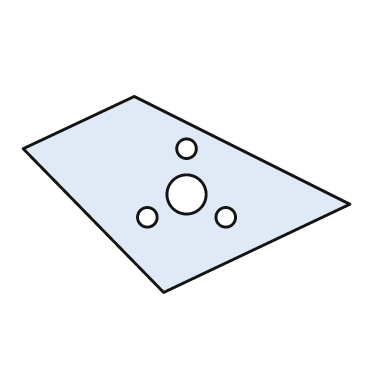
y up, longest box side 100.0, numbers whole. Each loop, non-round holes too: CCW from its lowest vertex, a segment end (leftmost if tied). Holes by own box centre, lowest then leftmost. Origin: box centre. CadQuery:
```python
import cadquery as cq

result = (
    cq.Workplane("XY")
    .moveTo(-7.0, -30.0)
    .lineTo(50.0, -3.0)
    .lineTo(-16.0, 30.0)
    .lineTo(-50.0, 14.0)
    .close()
    .moveTo(-12.0, -7.0)
    .circle(3.0)
    .moveTo(12.0, -7.0)
    .circle(3.0)
    .moveTo(0.0, 0.0)
    .circle(6.0)
    .moveTo(0.0, 14.0)
    .circle(3.0)
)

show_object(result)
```